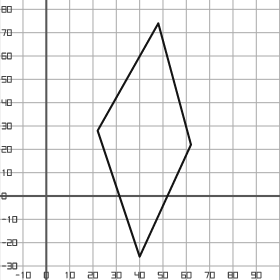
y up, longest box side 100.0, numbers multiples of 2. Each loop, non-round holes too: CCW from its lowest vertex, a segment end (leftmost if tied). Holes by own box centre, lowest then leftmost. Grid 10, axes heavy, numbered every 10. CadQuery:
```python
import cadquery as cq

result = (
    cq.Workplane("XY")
    .moveTo(40.0, -26.0)
    .lineTo(62.0, 22.0)
    .lineTo(48.0, 74.0)
    .lineTo(22.0, 28.0)
    .close()
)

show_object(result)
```